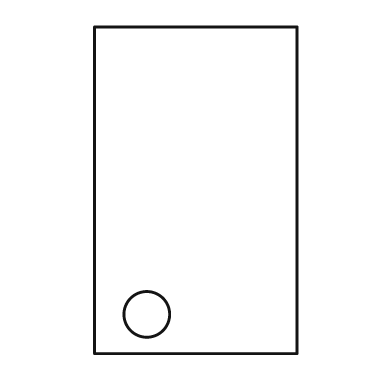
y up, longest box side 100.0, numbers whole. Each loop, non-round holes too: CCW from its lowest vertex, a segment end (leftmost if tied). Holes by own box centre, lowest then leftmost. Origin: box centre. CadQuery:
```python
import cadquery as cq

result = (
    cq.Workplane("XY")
    .moveTo(-31.0, -50.0)
    .lineTo(31.0, -50.0)
    .lineTo(31.0, 50.0)
    .lineTo(-31.0, 50.0)
    .close()
    .moveTo(-15.0, -38.0)
    .circle(7.0)
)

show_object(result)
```